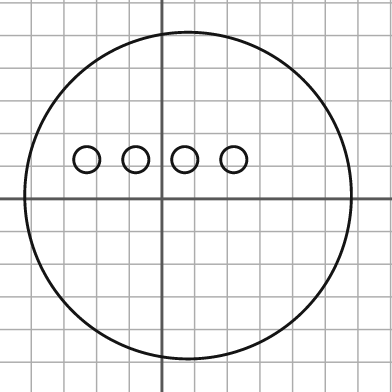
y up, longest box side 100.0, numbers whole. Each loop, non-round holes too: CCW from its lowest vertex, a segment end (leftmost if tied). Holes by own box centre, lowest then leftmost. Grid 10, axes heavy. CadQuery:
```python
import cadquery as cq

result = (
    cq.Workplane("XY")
    .moveTo(8.0, 1.0)
    .circle(50.0)
    .moveTo(-23.0, 12.0)
    .circle(4.0)
    .moveTo(-8.0, 12.0)
    .circle(4.0)
    .moveTo(7.0, 12.0)
    .circle(4.0)
    .moveTo(22.0, 12.0)
    .circle(4.0)
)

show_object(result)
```